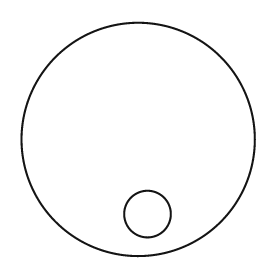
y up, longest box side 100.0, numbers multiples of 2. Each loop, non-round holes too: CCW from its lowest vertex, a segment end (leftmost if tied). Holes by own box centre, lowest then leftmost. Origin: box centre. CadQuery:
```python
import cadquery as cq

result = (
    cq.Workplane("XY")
    .moveTo(0.0, 0.0)
    .circle(50.0)
    .moveTo(4.0, -32.0)
    .circle(10.0)
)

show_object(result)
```